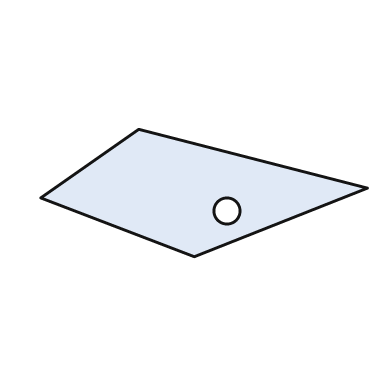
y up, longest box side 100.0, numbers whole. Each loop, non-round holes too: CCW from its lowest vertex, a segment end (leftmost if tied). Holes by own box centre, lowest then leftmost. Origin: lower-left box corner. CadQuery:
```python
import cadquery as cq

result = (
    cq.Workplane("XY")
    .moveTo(47.0, 0.0)
    .lineTo(100.0, 21.0)
    .lineTo(30.0, 39.0)
    .lineTo(0.0, 18.0)
    .close()
    .moveTo(57.0, 14.0)
    .circle(4.0)
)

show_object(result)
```